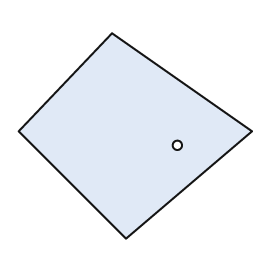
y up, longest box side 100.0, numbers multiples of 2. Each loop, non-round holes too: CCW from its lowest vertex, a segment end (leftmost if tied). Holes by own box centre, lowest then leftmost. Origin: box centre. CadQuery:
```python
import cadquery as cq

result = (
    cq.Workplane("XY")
    .moveTo(-4.0, -44.0)
    .lineTo(50.0, 2.0)
    .lineTo(-10.0, 44.0)
    .lineTo(-50.0, 2.0)
    .close()
    .moveTo(18.0, -4.0)
    .circle(2.0)
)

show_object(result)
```